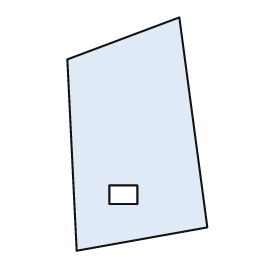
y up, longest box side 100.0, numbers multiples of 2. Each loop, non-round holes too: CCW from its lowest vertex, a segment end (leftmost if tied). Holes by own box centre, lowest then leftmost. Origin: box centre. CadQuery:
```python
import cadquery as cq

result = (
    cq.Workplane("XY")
    .moveTo(-26.0, -50.0)
    .lineTo(30.0, -40.0)
    .lineTo(18.0, 50.0)
    .lineTo(-30.0, 32.0)
    .close()
    .moveTo(-12.0, -30.0)
    .lineTo(0.0, -30.0)
    .lineTo(0.0, -22.0)
    .lineTo(-12.0, -22.0)
    .close()
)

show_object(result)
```